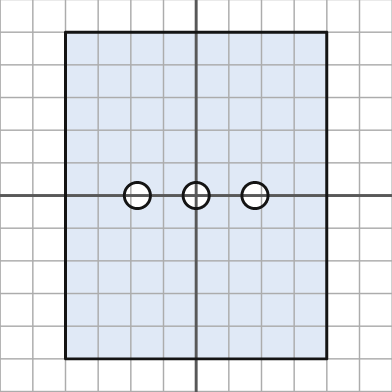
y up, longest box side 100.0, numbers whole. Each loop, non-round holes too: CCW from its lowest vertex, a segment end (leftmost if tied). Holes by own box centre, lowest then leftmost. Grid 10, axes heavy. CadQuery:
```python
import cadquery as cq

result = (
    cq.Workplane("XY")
    .moveTo(-40.0, -50.0)
    .lineTo(40.0, -50.0)
    .lineTo(40.0, 50.0)
    .lineTo(-40.0, 50.0)
    .close()
    .moveTo(-18.0, 0.0)
    .circle(4.0)
    .moveTo(0.0, 0.0)
    .circle(4.0)
    .moveTo(18.0, 0.0)
    .circle(4.0)
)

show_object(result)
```